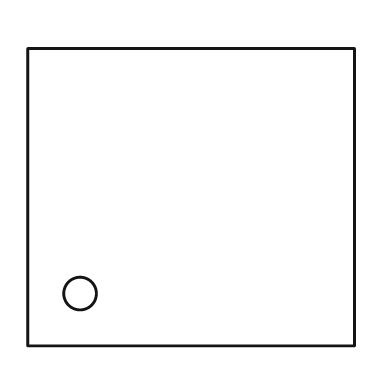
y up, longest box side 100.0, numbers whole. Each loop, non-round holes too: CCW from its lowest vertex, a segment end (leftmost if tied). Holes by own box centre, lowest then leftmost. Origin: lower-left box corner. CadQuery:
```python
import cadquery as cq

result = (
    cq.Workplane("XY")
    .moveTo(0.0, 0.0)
    .lineTo(100.0, 0.0)
    .lineTo(100.0, 91.0)
    .lineTo(0.0, 91.0)
    .close()
    .moveTo(16.0, 16.0)
    .circle(5.0)
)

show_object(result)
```